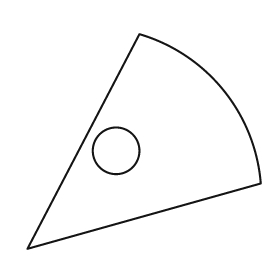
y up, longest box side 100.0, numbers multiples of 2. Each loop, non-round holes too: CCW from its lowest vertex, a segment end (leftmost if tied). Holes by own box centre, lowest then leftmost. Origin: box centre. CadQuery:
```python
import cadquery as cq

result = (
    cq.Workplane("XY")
    .moveTo(-50.0, -46.0)
    .lineTo(50.0, -18.0)
    .threePointArc((34.0, 22.0), (-2.0, 46.0))
    .close()
    .moveTo(-12.0, -4.0)
    .circle(10.0)
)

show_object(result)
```